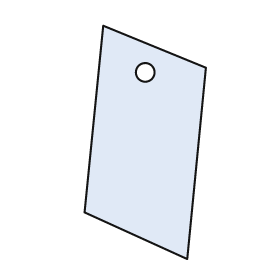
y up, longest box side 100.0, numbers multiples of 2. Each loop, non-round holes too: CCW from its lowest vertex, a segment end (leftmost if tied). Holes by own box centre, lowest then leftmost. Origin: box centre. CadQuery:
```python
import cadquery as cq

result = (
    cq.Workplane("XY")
    .moveTo(18.0, -50.0)
    .lineTo(26.0, 32.0)
    .lineTo(-18.0, 50.0)
    .lineTo(-26.0, -30.0)
    .close()
    .moveTo(0.0, 30.0)
    .circle(4.0)
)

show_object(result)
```